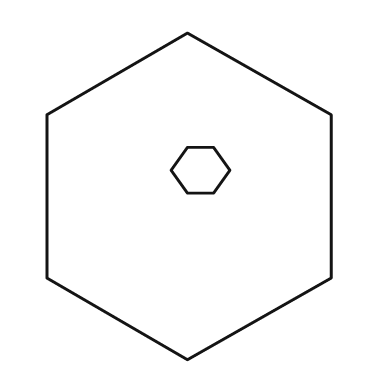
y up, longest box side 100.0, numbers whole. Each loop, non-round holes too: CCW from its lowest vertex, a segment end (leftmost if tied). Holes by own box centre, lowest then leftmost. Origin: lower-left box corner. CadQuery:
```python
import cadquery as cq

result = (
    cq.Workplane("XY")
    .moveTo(43.0, 0.0)
    .lineTo(87.0, 25.0)
    .lineTo(87.0, 75.0)
    .lineTo(43.0, 100.0)
    .lineTo(0.0, 75.0)
    .lineTo(0.0, 25.0)
    .close()
    .moveTo(43.0, 51.0)
    .lineTo(51.0, 51.0)
    .lineTo(56.0, 58.0)
    .lineTo(51.0, 65.0)
    .lineTo(43.0, 65.0)
    .lineTo(38.0, 58.0)
    .close()
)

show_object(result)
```